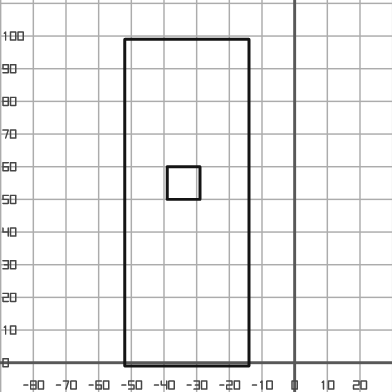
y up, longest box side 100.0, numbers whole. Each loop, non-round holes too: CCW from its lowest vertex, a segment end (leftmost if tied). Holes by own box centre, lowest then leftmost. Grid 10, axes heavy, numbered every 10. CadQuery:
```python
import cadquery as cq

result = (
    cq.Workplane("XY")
    .moveTo(-52.0, -1.0)
    .lineTo(-14.0, -1.0)
    .lineTo(-14.0, 99.0)
    .lineTo(-52.0, 99.0)
    .close()
    .moveTo(-39.0, 50.0)
    .lineTo(-29.0, 50.0)
    .lineTo(-29.0, 60.0)
    .lineTo(-39.0, 60.0)
    .close()
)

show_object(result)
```